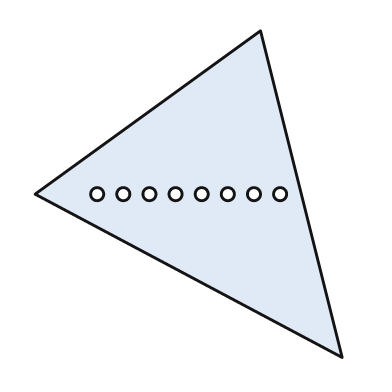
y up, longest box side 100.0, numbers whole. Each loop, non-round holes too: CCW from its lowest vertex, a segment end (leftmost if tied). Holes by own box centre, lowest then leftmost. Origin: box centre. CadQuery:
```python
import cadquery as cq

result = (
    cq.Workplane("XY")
    .moveTo(47.0, -50.0)
    .lineTo(22.0, 50.0)
    .lineTo(-47.0, 0.0)
    .close()
    .moveTo(-28.0, 0.0)
    .circle(2.0)
    .moveTo(-20.0, 0.0)
    .circle(2.0)
    .moveTo(-12.0, 0.0)
    .circle(2.0)
    .moveTo(-4.0, 0.0)
    .circle(2.0)
    .moveTo(4.0, 0.0)
    .circle(2.0)
    .moveTo(12.0, 0.0)
    .circle(2.0)
    .moveTo(20.0, 0.0)
    .circle(2.0)
    .moveTo(28.0, 0.0)
    .circle(2.0)
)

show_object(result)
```